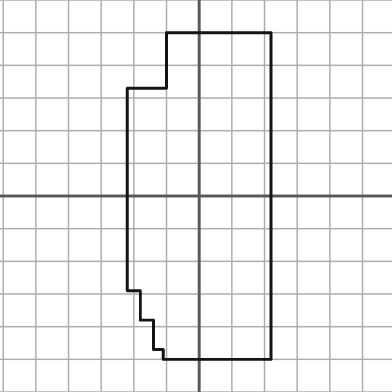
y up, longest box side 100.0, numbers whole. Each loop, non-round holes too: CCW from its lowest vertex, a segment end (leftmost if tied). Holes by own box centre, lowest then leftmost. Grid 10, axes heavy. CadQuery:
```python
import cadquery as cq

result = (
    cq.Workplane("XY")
    .moveTo(-11.0, -50.0)
    .lineTo(22.0, -50.0)
    .lineTo(22.0, 50.0)
    .lineTo(-10.0, 50.0)
    .lineTo(-10.0, 33.0)
    .lineTo(-22.0, 33.0)
    .lineTo(-22.0, -29.0)
    .lineTo(-18.0, -29.0)
    .lineTo(-18.0, -38.0)
    .lineTo(-14.0, -38.0)
    .lineTo(-14.0, -47.0)
    .lineTo(-11.0, -47.0)
    .close()
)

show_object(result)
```